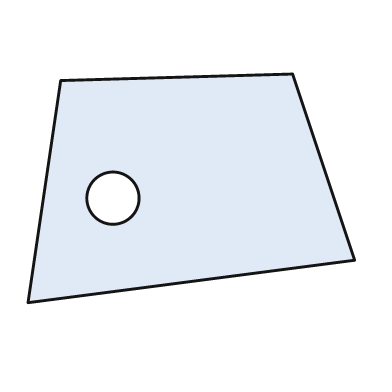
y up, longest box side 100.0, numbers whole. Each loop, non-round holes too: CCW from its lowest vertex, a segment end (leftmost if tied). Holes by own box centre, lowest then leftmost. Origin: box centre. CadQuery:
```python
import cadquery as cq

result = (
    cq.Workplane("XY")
    .moveTo(-50.0, -35.0)
    .lineTo(50.0, -22.0)
    .lineTo(31.0, 35.0)
    .lineTo(-40.0, 33.0)
    .close()
    .moveTo(-24.0, -3.0)
    .circle(8.0)
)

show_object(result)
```